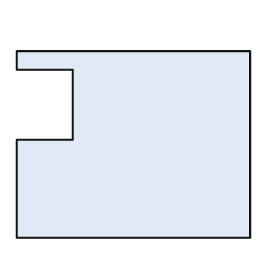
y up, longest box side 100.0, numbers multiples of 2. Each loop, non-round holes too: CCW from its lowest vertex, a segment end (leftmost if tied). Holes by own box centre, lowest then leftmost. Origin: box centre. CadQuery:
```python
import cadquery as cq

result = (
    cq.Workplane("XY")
    .moveTo(-50.0, -40.0)
    .lineTo(50.0, -40.0)
    .lineTo(50.0, 40.0)
    .lineTo(-50.0, 40.0)
    .lineTo(-50.0, 32.0)
    .lineTo(-26.0, 32.0)
    .lineTo(-26.0, 2.0)
    .lineTo(-50.0, 2.0)
    .close()
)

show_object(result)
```